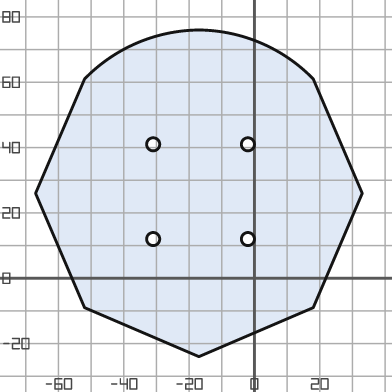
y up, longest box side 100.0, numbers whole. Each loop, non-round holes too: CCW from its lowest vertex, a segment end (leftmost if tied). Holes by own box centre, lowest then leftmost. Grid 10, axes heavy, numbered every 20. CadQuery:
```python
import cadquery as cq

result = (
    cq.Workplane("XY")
    .moveTo(-17.0, -24.0)
    .lineTo(18.0, -9.0)
    .lineTo(33.0, 26.0)
    .lineTo(18.0, 61.0)
    .threePointArc((2.0, 72.0), (-17.0, 76.0))
    .threePointArc((-36.0, 72.0), (-52.0, 61.0))
    .lineTo(-67.0, 26.0)
    .lineTo(-52.0, -9.0)
    .close()
    .moveTo(-31.0, 12.0)
    .circle(2.0)
    .moveTo(-2.0, 12.0)
    .circle(2.0)
    .moveTo(-31.0, 41.0)
    .circle(2.0)
    .moveTo(-2.0, 41.0)
    .circle(2.0)
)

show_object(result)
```